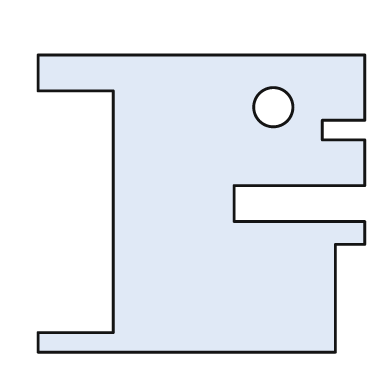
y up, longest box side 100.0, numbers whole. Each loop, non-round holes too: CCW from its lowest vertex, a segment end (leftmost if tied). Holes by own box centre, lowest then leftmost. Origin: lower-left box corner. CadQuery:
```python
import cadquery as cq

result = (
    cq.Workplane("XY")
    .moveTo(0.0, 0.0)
    .lineTo(91.0, 0.0)
    .lineTo(91.0, 33.0)
    .lineTo(100.0, 33.0)
    .lineTo(100.0, 40.0)
    .lineTo(60.0, 40.0)
    .lineTo(60.0, 51.0)
    .lineTo(100.0, 51.0)
    .lineTo(100.0, 65.0)
    .lineTo(87.0, 65.0)
    .lineTo(87.0, 71.0)
    .lineTo(100.0, 71.0)
    .lineTo(100.0, 91.0)
    .lineTo(0.0, 91.0)
    .lineTo(0.0, 80.0)
    .lineTo(23.0, 80.0)
    .lineTo(23.0, 6.0)
    .lineTo(0.0, 6.0)
    .close()
    .moveTo(72.0, 75.0)
    .circle(6.0)
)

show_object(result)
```